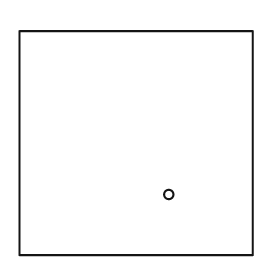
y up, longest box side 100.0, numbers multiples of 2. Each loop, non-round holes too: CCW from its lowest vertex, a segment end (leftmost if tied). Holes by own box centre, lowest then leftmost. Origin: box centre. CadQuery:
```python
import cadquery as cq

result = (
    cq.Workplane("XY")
    .moveTo(-50.0, -48.0)
    .lineTo(50.0, -48.0)
    .lineTo(50.0, 48.0)
    .lineTo(-50.0, 48.0)
    .close()
    .moveTo(14.0, -22.0)
    .circle(2.0)
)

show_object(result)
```